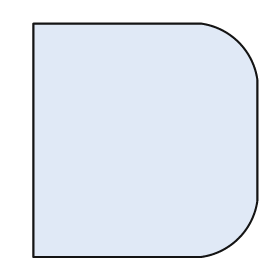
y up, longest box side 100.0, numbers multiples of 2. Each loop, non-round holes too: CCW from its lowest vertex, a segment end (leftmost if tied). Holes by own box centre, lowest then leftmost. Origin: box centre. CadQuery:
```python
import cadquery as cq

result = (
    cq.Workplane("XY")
    .moveTo(-48.0, -50.0)
    .lineTo(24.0, -50.0)
    .threePointArc((40.0, -42.0), (48.0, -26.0))
    .lineTo(48.0, 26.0)
    .threePointArc((40.0, 42.0), (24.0, 50.0))
    .lineTo(-48.0, 50.0)
    .close()
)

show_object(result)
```